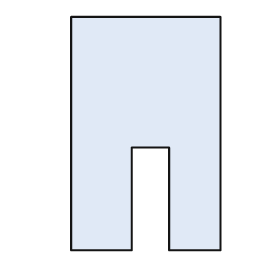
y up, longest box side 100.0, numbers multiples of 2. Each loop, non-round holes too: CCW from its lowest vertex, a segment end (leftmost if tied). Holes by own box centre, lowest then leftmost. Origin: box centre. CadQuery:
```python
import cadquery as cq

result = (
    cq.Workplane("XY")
    .moveTo(-32.0, -50.0)
    .lineTo(-6.0, -50.0)
    .lineTo(-6.0, -6.0)
    .lineTo(10.0, -6.0)
    .lineTo(10.0, -50.0)
    .lineTo(32.0, -50.0)
    .lineTo(32.0, 50.0)
    .lineTo(-32.0, 50.0)
    .close()
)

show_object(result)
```